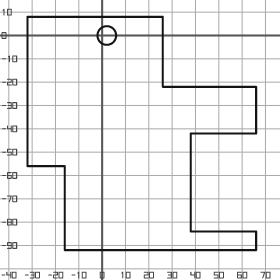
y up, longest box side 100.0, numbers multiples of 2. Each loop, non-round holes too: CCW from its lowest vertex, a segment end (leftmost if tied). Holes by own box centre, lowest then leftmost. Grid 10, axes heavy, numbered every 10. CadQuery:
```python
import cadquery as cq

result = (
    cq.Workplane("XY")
    .moveTo(-16.0, -92.0)
    .lineTo(66.0, -92.0)
    .lineTo(66.0, -84.0)
    .lineTo(38.0, -84.0)
    .lineTo(38.0, -42.0)
    .lineTo(66.0, -42.0)
    .lineTo(66.0, -22.0)
    .lineTo(26.0, -22.0)
    .lineTo(26.0, 8.0)
    .lineTo(-32.0, 8.0)
    .lineTo(-32.0, -56.0)
    .lineTo(-16.0, -56.0)
    .close()
    .moveTo(2.0, 0.0)
    .circle(4.0)
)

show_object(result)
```